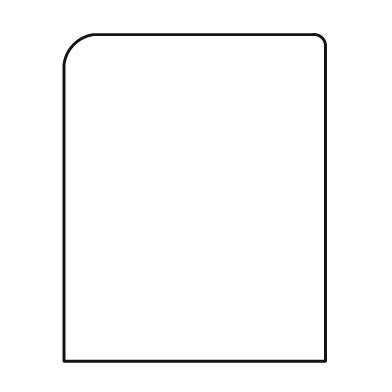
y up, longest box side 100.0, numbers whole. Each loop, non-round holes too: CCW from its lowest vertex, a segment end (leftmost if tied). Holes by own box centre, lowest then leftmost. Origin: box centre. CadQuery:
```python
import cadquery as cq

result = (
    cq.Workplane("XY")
    .moveTo(-40.0, -50.0)
    .lineTo(40.0, -50.0)
    .lineTo(40.0, 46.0)
    .threePointArc((39.0, 49.0), (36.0, 50.0))
    .lineTo(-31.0, 50.0)
    .threePointArc((-37.0, 47.0), (-40.0, 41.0))
    .close()
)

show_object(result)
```